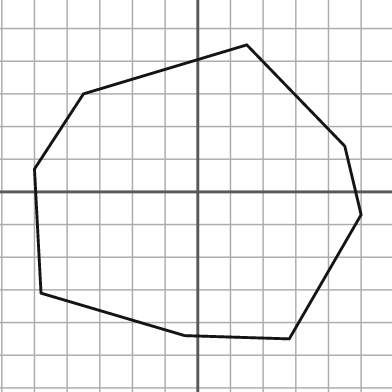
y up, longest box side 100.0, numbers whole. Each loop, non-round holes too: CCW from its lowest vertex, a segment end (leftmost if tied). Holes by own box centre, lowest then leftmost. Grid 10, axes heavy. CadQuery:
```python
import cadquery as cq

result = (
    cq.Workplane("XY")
    .moveTo(28.0, -45.0)
    .lineTo(50.0, -7.0)
    .lineTo(45.0, 14.0)
    .lineTo(15.0, 45.0)
    .lineTo(-35.0, 30.0)
    .lineTo(-50.0, 7.0)
    .lineTo(-48.0, -31.0)
    .lineTo(-4.0, -44.0)
    .close()
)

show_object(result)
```